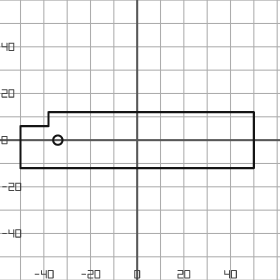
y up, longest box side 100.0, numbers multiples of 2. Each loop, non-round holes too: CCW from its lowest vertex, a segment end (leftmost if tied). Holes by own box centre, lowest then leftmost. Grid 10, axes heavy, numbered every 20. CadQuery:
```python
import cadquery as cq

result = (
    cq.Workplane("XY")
    .moveTo(-50.0, -12.0)
    .lineTo(50.0, -12.0)
    .lineTo(50.0, 12.0)
    .lineTo(-38.0, 12.0)
    .lineTo(-38.0, 6.0)
    .lineTo(-50.0, 6.0)
    .close()
    .moveTo(-34.0, 0.0)
    .circle(2.0)
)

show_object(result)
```